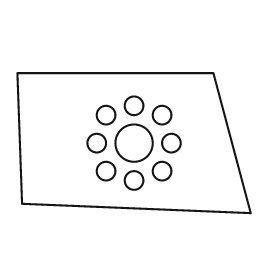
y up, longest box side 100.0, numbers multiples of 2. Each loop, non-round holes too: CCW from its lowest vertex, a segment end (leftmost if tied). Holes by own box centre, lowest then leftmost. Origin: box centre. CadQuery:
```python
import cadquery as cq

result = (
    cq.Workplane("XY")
    .moveTo(50.0, -30.0)
    .lineTo(34.0, 30.0)
    .lineTo(-50.0, 30.0)
    .lineTo(-48.0, -26.0)
    .close()
    .moveTo(0.0, -16.0)
    .circle(4.0)
    .moveTo(-12.0, -12.0)
    .circle(4.0)
    .moveTo(12.0, -12.0)
    .circle(4.0)
    .moveTo(-16.0, 0.0)
    .circle(4.0)
    .moveTo(0.0, 0.0)
    .circle(8.0)
    .moveTo(16.0, 0.0)
    .circle(4.0)
    .moveTo(-12.0, 12.0)
    .circle(4.0)
    .moveTo(12.0, 12.0)
    .circle(4.0)
    .moveTo(0.0, 16.0)
    .circle(4.0)
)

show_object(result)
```